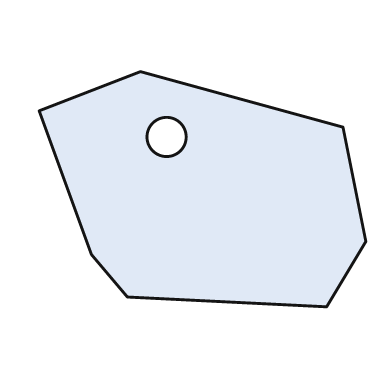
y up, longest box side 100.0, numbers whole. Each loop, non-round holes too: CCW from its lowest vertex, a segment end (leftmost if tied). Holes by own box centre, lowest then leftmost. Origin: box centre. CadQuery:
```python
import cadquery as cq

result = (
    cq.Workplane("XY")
    .moveTo(38.0, -36.0)
    .lineTo(50.0, -16.0)
    .lineTo(43.0, 19.0)
    .lineTo(-19.0, 36.0)
    .lineTo(-50.0, 24.0)
    .lineTo(-34.0, -20.0)
    .lineTo(-23.0, -33.0)
    .close()
    .moveTo(-11.0, 16.0)
    .circle(6.0)
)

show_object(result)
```